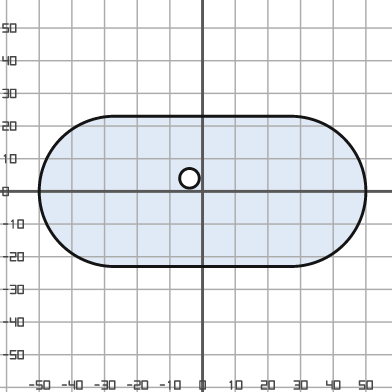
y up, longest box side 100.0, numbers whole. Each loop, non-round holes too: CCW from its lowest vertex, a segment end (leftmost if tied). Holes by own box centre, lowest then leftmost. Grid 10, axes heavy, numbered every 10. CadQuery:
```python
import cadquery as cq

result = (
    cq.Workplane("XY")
    .moveTo(-27.0, -23.0)
    .lineTo(27.0, -23.0)
    .threePointArc((50.0, 0.0), (27.0, 23.0))
    .lineTo(-27.0, 23.0)
    .threePointArc((-50.0, 0.0), (-27.0, -23.0))
    .close()
    .moveTo(-4.0, 4.0)
    .circle(3.0)
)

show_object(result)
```